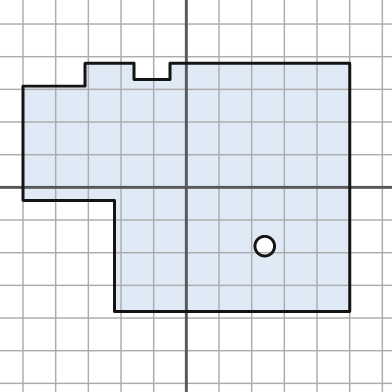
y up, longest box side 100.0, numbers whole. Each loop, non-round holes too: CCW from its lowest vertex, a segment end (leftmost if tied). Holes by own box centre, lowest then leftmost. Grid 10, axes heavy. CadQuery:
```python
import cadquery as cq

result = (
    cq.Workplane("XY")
    .moveTo(-22.0, -38.0)
    .lineTo(50.0, -38.0)
    .lineTo(50.0, 38.0)
    .lineTo(-5.0, 38.0)
    .lineTo(-5.0, 33.0)
    .lineTo(-16.0, 33.0)
    .lineTo(-16.0, 38.0)
    .lineTo(-31.0, 38.0)
    .lineTo(-31.0, 31.0)
    .lineTo(-50.0, 31.0)
    .lineTo(-50.0, -4.0)
    .lineTo(-22.0, -4.0)
    .close()
    .moveTo(24.0, -18.0)
    .circle(3.0)
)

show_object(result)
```